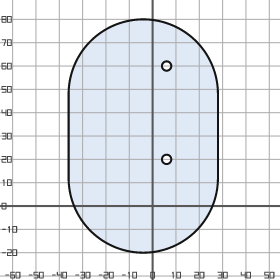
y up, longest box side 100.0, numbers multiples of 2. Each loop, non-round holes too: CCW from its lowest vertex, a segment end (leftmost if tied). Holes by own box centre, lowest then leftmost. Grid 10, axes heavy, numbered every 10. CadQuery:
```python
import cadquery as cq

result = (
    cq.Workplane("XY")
    .moveTo(-36.0, 12.0)
    .threePointArc((-4.0, -20.0), (28.0, 12.0))
    .lineTo(28.0, 48.0)
    .threePointArc((-4.0, 80.0), (-36.0, 48.0))
    .close()
    .moveTo(6.0, 20.0)
    .circle(2.0)
    .moveTo(6.0, 60.0)
    .circle(2.0)
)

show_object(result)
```